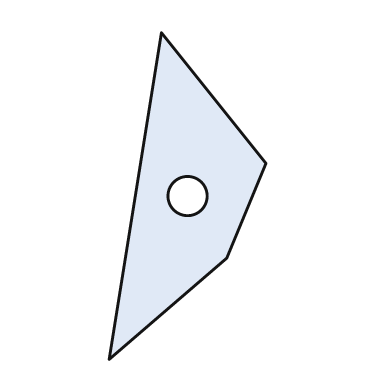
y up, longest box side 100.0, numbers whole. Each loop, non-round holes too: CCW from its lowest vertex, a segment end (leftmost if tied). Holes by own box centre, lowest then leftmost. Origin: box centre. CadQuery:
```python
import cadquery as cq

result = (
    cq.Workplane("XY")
    .moveTo(-24.0, -50.0)
    .lineTo(12.0, -19.0)
    .lineTo(24.0, 10.0)
    .lineTo(-8.0, 50.0)
    .close()
    .moveTo(0.0, 0.0)
    .circle(6.0)
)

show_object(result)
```